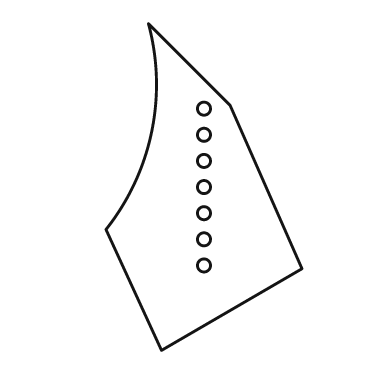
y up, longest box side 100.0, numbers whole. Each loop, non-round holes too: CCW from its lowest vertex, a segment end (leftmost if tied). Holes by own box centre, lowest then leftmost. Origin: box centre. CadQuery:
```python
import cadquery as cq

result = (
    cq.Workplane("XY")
    .moveTo(-13.0, -50.0)
    .lineTo(30.0, -25.0)
    .lineTo(8.0, 25.0)
    .lineTo(-17.0, 50.0)
    .threePointArc((-16.0, 17.0), (-30.0, -13.0))
    .close()
    .moveTo(0.0, -24.0)
    .circle(2.0)
    .moveTo(0.0, -16.0)
    .circle(2.0)
    .moveTo(0.0, -8.0)
    .circle(2.0)
    .moveTo(0.0, 0.0)
    .circle(2.0)
    .moveTo(0.0, 8.0)
    .circle(2.0)
    .moveTo(0.0, 16.0)
    .circle(2.0)
    .moveTo(0.0, 24.0)
    .circle(2.0)
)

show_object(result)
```